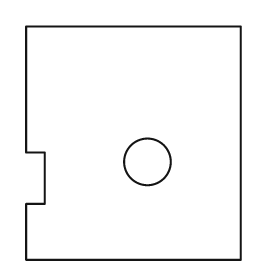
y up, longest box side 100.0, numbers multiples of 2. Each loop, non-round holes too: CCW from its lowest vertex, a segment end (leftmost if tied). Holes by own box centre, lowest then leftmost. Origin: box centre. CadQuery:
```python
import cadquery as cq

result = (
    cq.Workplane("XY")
    .moveTo(-46.0, -50.0)
    .lineTo(46.0, -50.0)
    .lineTo(46.0, 50.0)
    .lineTo(-46.0, 50.0)
    .lineTo(-46.0, -4.0)
    .lineTo(-38.0, -4.0)
    .lineTo(-38.0, -26.0)
    .lineTo(-46.0, -26.0)
    .close()
    .moveTo(6.0, -8.0)
    .circle(10.0)
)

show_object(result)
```